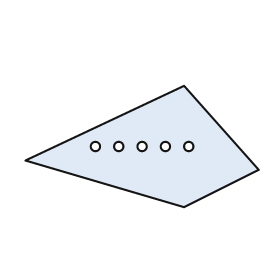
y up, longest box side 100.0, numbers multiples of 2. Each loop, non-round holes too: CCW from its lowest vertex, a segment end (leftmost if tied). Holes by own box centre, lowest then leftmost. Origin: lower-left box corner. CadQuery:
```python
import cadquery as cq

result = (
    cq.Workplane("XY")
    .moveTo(68.0, 0.0)
    .lineTo(100.0, 16.0)
    .lineTo(68.0, 52.0)
    .lineTo(0.0, 20.0)
    .close()
    .moveTo(30.0, 26.0)
    .circle(2.0)
    .moveTo(40.0, 26.0)
    .circle(2.0)
    .moveTo(50.0, 26.0)
    .circle(2.0)
    .moveTo(60.0, 26.0)
    .circle(2.0)
    .moveTo(70.0, 26.0)
    .circle(2.0)
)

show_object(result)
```